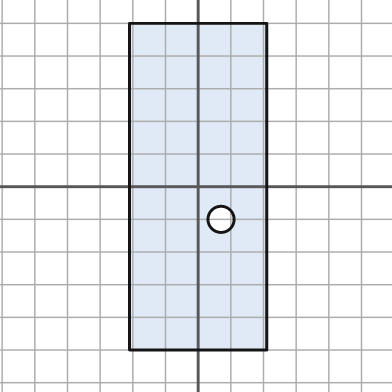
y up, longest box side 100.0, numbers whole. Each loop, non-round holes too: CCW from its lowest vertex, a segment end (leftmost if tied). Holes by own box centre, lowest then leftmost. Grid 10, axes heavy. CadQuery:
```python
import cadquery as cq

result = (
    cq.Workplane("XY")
    .moveTo(-21.0, -50.0)
    .lineTo(21.0, -50.0)
    .lineTo(21.0, 50.0)
    .lineTo(-21.0, 50.0)
    .close()
    .moveTo(7.0, -10.0)
    .circle(4.0)
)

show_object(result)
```